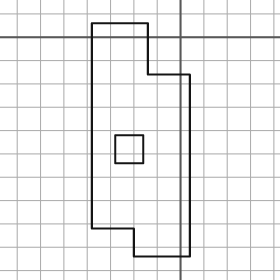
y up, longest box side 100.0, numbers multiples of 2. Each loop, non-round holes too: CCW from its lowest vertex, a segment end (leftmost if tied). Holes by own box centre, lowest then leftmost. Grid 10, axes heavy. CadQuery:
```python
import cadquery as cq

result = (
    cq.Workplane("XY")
    .moveTo(-20.0, -94.0)
    .lineTo(4.0, -94.0)
    .lineTo(4.0, -16.0)
    .lineTo(-14.0, -16.0)
    .lineTo(-14.0, 6.0)
    .lineTo(-38.0, 6.0)
    .lineTo(-38.0, -82.0)
    .lineTo(-20.0, -82.0)
    .close()
    .moveTo(-28.0, -54.0)
    .lineTo(-16.0, -54.0)
    .lineTo(-16.0, -42.0)
    .lineTo(-28.0, -42.0)
    .close()
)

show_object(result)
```